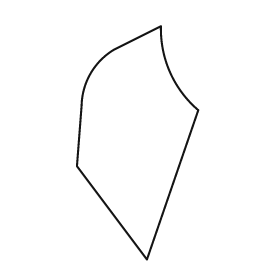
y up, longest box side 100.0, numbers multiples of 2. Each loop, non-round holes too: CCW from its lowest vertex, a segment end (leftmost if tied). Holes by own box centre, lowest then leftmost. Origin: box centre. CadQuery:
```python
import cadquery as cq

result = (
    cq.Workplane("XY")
    .moveTo(4.0, -50.0)
    .lineTo(26.0, 14.0)
    .threePointArc((14.0, 30.0), (10.0, 50.0))
    .lineTo(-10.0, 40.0)
    .threePointArc((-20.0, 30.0), (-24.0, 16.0))
    .lineTo(-26.0, -10.0)
    .close()
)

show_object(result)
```